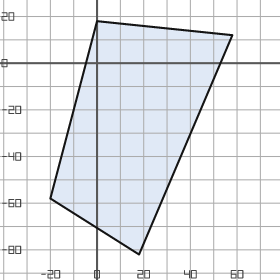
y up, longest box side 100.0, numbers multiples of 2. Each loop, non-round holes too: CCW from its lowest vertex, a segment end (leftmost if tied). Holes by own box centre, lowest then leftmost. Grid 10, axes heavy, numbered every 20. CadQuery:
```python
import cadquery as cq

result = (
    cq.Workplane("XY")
    .moveTo(18.0, -82.0)
    .lineTo(58.0, 12.0)
    .lineTo(0.0, 18.0)
    .lineTo(-20.0, -58.0)
    .close()
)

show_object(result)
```